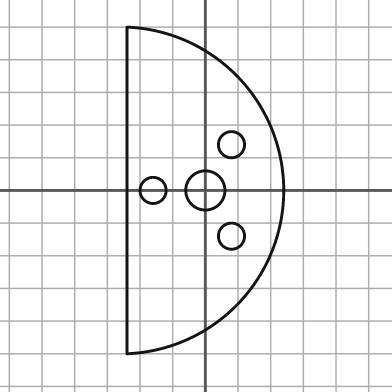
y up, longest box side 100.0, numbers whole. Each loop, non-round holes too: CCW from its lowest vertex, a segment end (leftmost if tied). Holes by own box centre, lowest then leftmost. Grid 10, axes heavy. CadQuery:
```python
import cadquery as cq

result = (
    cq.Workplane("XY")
    .moveTo(-24.0, -50.0)
    .threePointArc((24.0, 0.0), (-24.0, 50.0))
    .close()
    .moveTo(8.0, -14.0)
    .circle(4.0)
    .moveTo(-16.0, 0.0)
    .circle(4.0)
    .moveTo(0.0, 0.0)
    .circle(6.0)
    .moveTo(8.0, 14.0)
    .circle(4.0)
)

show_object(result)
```